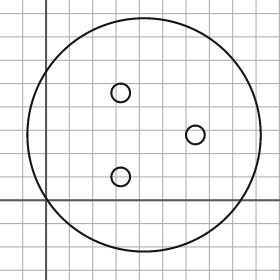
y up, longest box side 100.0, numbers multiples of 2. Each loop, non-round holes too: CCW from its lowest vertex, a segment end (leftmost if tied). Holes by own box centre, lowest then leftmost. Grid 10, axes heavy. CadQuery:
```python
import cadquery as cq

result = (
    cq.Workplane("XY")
    .moveTo(42.0, 28.0)
    .circle(50.0)
    .moveTo(32.0, 10.0)
    .circle(4.0)
    .moveTo(64.0, 28.0)
    .circle(4.0)
    .moveTo(32.0, 46.0)
    .circle(4.0)
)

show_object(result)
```